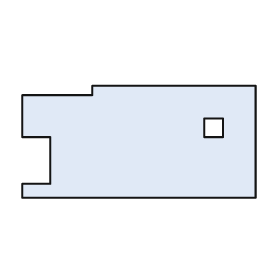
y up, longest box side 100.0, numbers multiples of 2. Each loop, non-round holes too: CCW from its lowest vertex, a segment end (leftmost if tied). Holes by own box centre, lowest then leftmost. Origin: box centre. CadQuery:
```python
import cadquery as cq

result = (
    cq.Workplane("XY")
    .moveTo(-50.0, -24.0)
    .lineTo(50.0, -24.0)
    .lineTo(50.0, 24.0)
    .lineTo(-20.0, 24.0)
    .lineTo(-20.0, 20.0)
    .lineTo(-50.0, 20.0)
    .lineTo(-50.0, 2.0)
    .lineTo(-38.0, 2.0)
    .lineTo(-38.0, -18.0)
    .lineTo(-50.0, -18.0)
    .close()
    .moveTo(28.0, 2.0)
    .lineTo(36.0, 2.0)
    .lineTo(36.0, 10.0)
    .lineTo(28.0, 10.0)
    .close()
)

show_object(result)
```